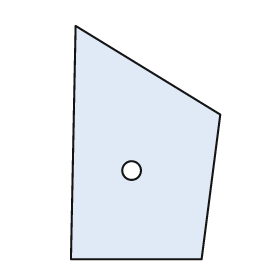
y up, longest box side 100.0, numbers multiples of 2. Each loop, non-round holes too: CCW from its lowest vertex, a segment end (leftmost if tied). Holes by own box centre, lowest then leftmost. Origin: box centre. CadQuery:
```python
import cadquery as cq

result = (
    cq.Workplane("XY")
    .moveTo(-32.0, -50.0)
    .lineTo(24.0, -50.0)
    .lineTo(32.0, 12.0)
    .lineTo(-30.0, 50.0)
    .close()
    .moveTo(-6.0, -12.0)
    .circle(4.0)
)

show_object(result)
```